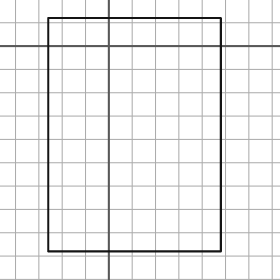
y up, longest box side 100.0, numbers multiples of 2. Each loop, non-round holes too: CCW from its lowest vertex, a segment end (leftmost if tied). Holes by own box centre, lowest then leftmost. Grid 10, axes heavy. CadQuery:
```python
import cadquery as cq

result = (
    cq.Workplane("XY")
    .moveTo(-26.0, -88.0)
    .lineTo(48.0, -88.0)
    .lineTo(48.0, 12.0)
    .lineTo(-26.0, 12.0)
    .close()
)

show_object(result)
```